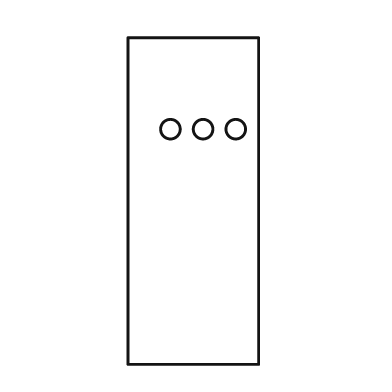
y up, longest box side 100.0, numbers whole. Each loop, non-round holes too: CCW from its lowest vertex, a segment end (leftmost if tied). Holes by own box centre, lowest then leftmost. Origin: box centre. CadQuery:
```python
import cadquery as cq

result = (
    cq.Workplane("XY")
    .moveTo(-20.0, -50.0)
    .lineTo(20.0, -50.0)
    .lineTo(20.0, 50.0)
    .lineTo(-20.0, 50.0)
    .close()
    .moveTo(-7.0, 22.0)
    .circle(3.0)
    .moveTo(3.0, 22.0)
    .circle(3.0)
    .moveTo(13.0, 22.0)
    .circle(3.0)
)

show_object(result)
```